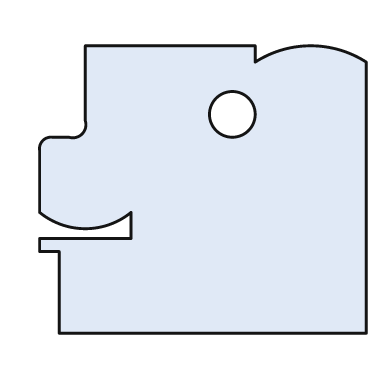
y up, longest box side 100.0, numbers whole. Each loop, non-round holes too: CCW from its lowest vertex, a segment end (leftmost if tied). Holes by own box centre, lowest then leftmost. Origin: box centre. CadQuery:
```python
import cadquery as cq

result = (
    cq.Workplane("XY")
    .moveTo(-44.0, -44.0)
    .lineTo(50.0, -44.0)
    .lineTo(50.0, 39.0)
    .threePointArc((33.0, 44.0), (16.0, 39.0))
    .lineTo(16.0, 44.0)
    .lineTo(-36.0, 44.0)
    .lineTo(-36.0, 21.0)
    .threePointArc((-37.0, 17.0), (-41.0, 16.0))
    .lineTo(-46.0, 16.0)
    .threePointArc((-49.0, 15.0), (-50.0, 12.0))
    .lineTo(-50.0, -7.0)
    .threePointArc((-36.0, -12.0), (-22.0, -7.0))
    .lineTo(-22.0, -15.0)
    .lineTo(-50.0, -15.0)
    .lineTo(-50.0, -19.0)
    .lineTo(-44.0, -19.0)
    .close()
    .moveTo(9.0, 23.0)
    .circle(7.0)
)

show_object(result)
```